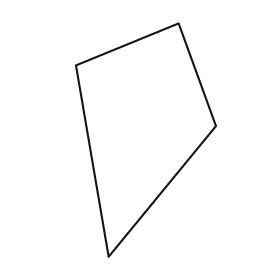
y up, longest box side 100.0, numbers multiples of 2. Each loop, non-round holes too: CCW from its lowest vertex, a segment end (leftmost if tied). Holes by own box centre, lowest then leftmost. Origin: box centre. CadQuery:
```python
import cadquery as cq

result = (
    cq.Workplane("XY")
    .moveTo(-16.0, -50.0)
    .lineTo(30.0, 6.0)
    .lineTo(14.0, 50.0)
    .lineTo(-30.0, 32.0)
    .close()
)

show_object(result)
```